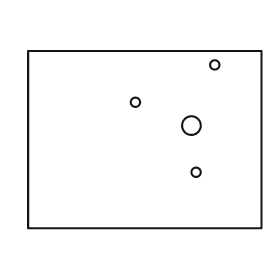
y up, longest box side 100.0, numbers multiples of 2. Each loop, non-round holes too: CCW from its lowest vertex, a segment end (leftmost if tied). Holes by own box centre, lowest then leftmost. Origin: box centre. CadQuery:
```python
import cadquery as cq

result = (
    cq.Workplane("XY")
    .moveTo(-50.0, -38.0)
    .lineTo(50.0, -38.0)
    .lineTo(50.0, 38.0)
    .lineTo(-50.0, 38.0)
    .close()
    .moveTo(22.0, -14.0)
    .circle(2.0)
    .moveTo(20.0, 6.0)
    .circle(4.0)
    .moveTo(-4.0, 16.0)
    .circle(2.0)
    .moveTo(30.0, 32.0)
    .circle(2.0)
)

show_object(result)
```